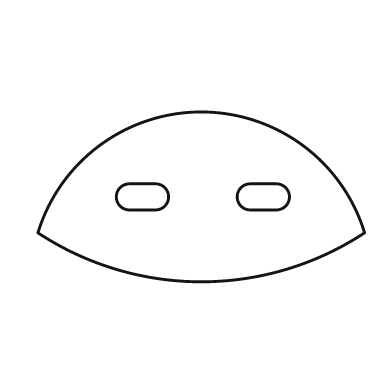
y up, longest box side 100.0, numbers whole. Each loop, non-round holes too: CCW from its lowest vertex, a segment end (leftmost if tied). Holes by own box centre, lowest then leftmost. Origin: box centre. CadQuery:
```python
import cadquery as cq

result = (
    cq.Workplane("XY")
    .moveTo(-50.0, -11.0)
    .threePointArc((0.0, -26.0), (50.0, -11.0))
    .threePointArc((0.0, 26.0), (-50.0, -11.0))
    .close()
    .moveTo(-22.0, -4.0)
    .lineTo(-14.0, -4.0)
    .threePointArc((-10.0, 0.0), (-14.0, 4.0))
    .lineTo(-22.0, 4.0)
    .threePointArc((-26.0, 0.0), (-22.0, -4.0))
    .close()
    .moveTo(15.0, -4.0)
    .lineTo(23.0, -4.0)
    .threePointArc((27.0, 0.0), (23.0, 4.0))
    .lineTo(15.0, 4.0)
    .threePointArc((11.0, 0.0), (15.0, -4.0))
    .close()
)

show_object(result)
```